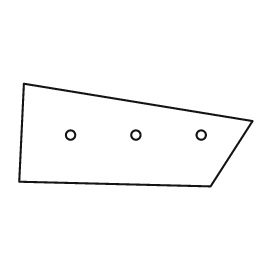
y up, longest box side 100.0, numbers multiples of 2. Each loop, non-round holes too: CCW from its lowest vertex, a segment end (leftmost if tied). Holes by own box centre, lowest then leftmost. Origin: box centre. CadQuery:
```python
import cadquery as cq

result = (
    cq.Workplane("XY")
    .moveTo(32.0, -22.0)
    .lineTo(50.0, 6.0)
    .lineTo(-48.0, 22.0)
    .lineTo(-50.0, -20.0)
    .close()
    .moveTo(-28.0, 0.0)
    .circle(2.0)
    .moveTo(0.0, 0.0)
    .circle(2.0)
    .moveTo(28.0, 0.0)
    .circle(2.0)
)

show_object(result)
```